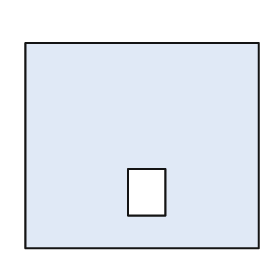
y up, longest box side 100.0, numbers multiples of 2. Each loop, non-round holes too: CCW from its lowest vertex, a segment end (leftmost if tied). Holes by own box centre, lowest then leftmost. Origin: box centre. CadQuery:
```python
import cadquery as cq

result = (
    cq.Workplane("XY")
    .moveTo(-50.0, -44.0)
    .lineTo(50.0, -44.0)
    .lineTo(50.0, 44.0)
    .lineTo(-50.0, 44.0)
    .close()
    .moveTo(-6.0, -30.0)
    .lineTo(10.0, -30.0)
    .lineTo(10.0, -10.0)
    .lineTo(-6.0, -10.0)
    .close()
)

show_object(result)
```